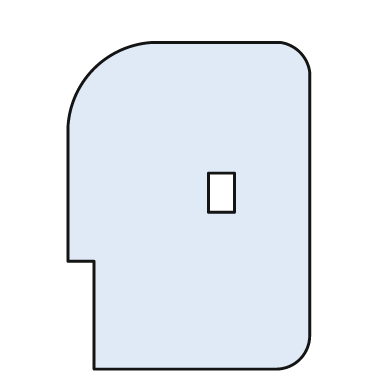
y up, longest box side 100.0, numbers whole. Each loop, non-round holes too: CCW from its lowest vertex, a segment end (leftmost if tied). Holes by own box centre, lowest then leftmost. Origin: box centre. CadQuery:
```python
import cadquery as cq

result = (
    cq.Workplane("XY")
    .moveTo(-29.0, -50.0)
    .lineTo(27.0, -50.0)
    .threePointArc((34.0, -47.0), (37.0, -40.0))
    .lineTo(37.0, 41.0)
    .threePointArc((34.0, 47.0), (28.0, 50.0))
    .lineTo(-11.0, 50.0)
    .threePointArc((-29.0, 42.0), (-37.0, 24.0))
    .lineTo(-37.0, -17.0)
    .lineTo(-29.0, -17.0)
    .close()
    .moveTo(6.0, -2.0)
    .lineTo(14.0, -2.0)
    .lineTo(14.0, 10.0)
    .lineTo(6.0, 10.0)
    .close()
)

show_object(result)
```